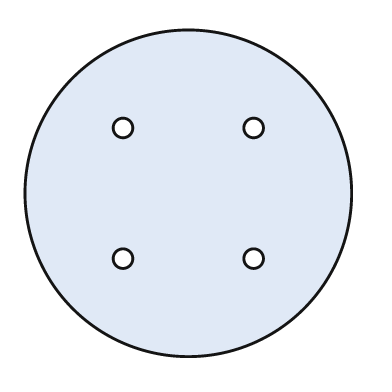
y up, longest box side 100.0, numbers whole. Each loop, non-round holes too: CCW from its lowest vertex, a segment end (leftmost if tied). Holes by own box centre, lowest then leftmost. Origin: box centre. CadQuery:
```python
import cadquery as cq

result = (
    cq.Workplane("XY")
    .moveTo(0.0, 0.0)
    .circle(50.0)
    .moveTo(-20.0, -20.0)
    .circle(3.0)
    .moveTo(20.0, -20.0)
    .circle(3.0)
    .moveTo(-20.0, 20.0)
    .circle(3.0)
    .moveTo(20.0, 20.0)
    .circle(3.0)
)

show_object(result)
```